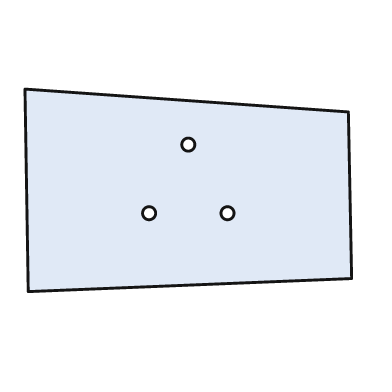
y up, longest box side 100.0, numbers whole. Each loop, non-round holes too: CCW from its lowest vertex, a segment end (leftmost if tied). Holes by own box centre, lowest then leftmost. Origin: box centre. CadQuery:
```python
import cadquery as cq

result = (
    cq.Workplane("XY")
    .moveTo(-49.0, -31.0)
    .lineTo(50.0, -27.0)
    .lineTo(49.0, 24.0)
    .lineTo(-50.0, 31.0)
    .close()
    .moveTo(-12.0, -7.0)
    .circle(2.0)
    .moveTo(12.0, -7.0)
    .circle(2.0)
    .moveTo(0.0, 14.0)
    .circle(2.0)
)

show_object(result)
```